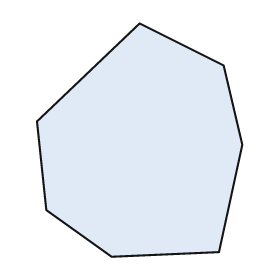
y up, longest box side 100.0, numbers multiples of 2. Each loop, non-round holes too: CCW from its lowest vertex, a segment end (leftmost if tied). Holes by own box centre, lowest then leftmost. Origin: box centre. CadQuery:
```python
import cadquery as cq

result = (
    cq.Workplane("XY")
    .moveTo(-12.0, -50.0)
    .lineTo(34.0, -48.0)
    .lineTo(44.0, -2.0)
    .lineTo(36.0, 32.0)
    .lineTo(0.0, 50.0)
    .lineTo(-44.0, 8.0)
    .lineTo(-40.0, -30.0)
    .close()
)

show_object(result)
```